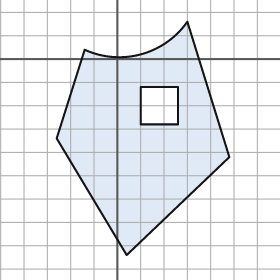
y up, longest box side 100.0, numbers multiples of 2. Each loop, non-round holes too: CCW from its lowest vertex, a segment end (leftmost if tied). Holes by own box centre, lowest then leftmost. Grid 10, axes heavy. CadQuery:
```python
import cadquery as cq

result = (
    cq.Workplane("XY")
    .moveTo(4.0, -84.0)
    .lineTo(48.0, -42.0)
    .lineTo(30.0, 16.0)
    .threePointArc((10.0, 2.0), (-14.0, 4.0))
    .lineTo(-26.0, -34.0)
    .close()
    .moveTo(10.0, -28.0)
    .lineTo(26.0, -28.0)
    .lineTo(26.0, -12.0)
    .lineTo(10.0, -12.0)
    .close()
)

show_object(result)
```